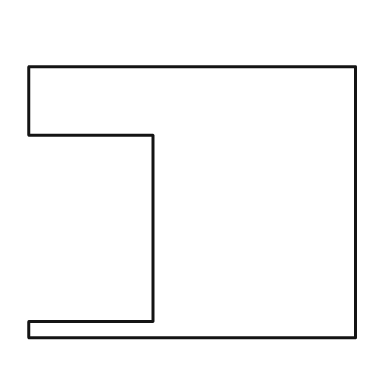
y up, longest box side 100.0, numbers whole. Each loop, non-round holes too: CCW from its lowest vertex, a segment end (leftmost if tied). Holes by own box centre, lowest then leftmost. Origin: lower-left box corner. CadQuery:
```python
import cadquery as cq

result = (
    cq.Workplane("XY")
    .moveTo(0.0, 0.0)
    .lineTo(100.0, 0.0)
    .lineTo(100.0, 83.0)
    .lineTo(0.0, 83.0)
    .lineTo(0.0, 62.0)
    .lineTo(38.0, 62.0)
    .lineTo(38.0, 5.0)
    .lineTo(0.0, 5.0)
    .close()
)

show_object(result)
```